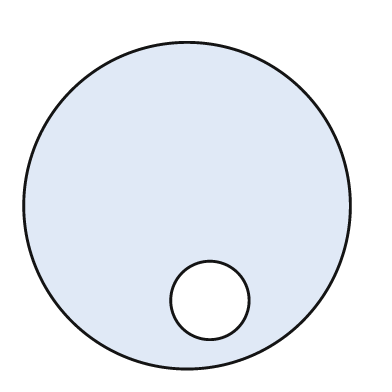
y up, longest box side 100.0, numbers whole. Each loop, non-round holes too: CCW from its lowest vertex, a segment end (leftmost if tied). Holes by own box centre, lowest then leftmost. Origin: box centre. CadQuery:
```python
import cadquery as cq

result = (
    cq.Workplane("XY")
    .moveTo(0.0, 0.0)
    .circle(50.0)
    .moveTo(7.0, -29.0)
    .circle(12.0)
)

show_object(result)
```